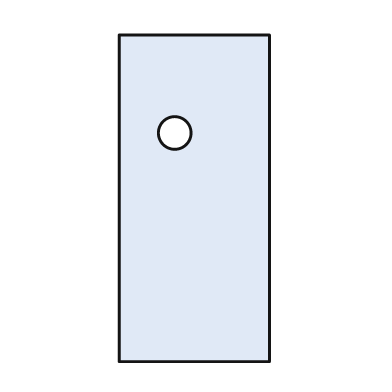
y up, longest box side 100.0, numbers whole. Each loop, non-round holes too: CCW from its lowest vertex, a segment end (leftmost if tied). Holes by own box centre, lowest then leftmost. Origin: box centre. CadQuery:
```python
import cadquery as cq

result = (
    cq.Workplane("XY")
    .moveTo(-23.0, -50.0)
    .lineTo(23.0, -50.0)
    .lineTo(23.0, 50.0)
    .lineTo(-23.0, 50.0)
    .close()
    .moveTo(-6.0, 20.0)
    .circle(5.0)
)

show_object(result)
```